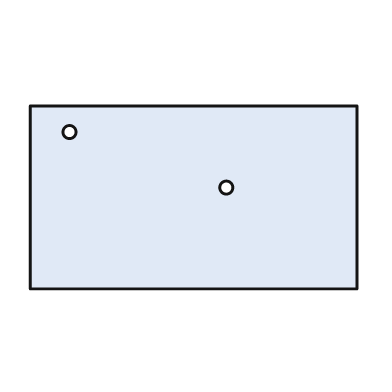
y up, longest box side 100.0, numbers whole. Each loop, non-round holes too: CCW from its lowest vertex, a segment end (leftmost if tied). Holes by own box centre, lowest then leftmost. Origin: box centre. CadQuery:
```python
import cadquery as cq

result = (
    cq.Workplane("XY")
    .moveTo(-50.0, -28.0)
    .lineTo(50.0, -28.0)
    .lineTo(50.0, 28.0)
    .lineTo(-50.0, 28.0)
    .close()
    .moveTo(10.0, 3.0)
    .circle(2.0)
    .moveTo(-38.0, 20.0)
    .circle(2.0)
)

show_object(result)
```